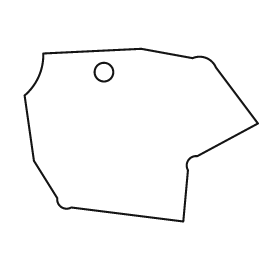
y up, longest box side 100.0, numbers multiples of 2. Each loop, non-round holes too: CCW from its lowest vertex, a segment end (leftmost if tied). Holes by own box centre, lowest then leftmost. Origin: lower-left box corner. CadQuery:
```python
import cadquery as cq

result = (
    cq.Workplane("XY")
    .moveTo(68.0, 0.0)
    .lineTo(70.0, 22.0)
    .threePointArc((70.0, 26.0), (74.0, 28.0))
    .lineTo(100.0, 42.0)
    .lineTo(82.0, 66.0)
    .threePointArc((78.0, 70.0), (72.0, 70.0))
    .lineTo(50.0, 74.0)
    .lineTo(8.0, 72.0)
    .threePointArc((6.0, 62.0), (0.0, 54.0))
    .lineTo(4.0, 26.0)
    .lineTo(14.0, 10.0)
    .threePointArc((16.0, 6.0), (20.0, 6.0))
    .close()
    .moveTo(34.0, 64.0)
    .circle(4.0)
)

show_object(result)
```